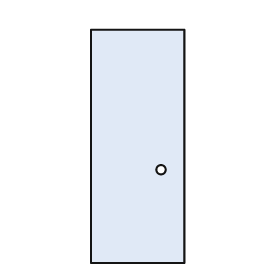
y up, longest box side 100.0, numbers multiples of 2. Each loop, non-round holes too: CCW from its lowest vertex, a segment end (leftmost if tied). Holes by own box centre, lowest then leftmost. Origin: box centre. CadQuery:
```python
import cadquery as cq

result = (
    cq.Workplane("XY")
    .moveTo(-20.0, -50.0)
    .lineTo(20.0, -50.0)
    .lineTo(20.0, 50.0)
    .lineTo(-20.0, 50.0)
    .close()
    .moveTo(10.0, -10.0)
    .circle(2.0)
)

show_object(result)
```